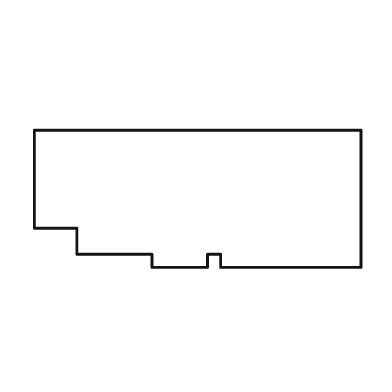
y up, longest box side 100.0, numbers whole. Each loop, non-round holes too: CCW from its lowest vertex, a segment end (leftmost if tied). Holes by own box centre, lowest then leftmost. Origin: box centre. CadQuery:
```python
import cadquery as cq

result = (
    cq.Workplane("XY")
    .moveTo(-14.0, -21.0)
    .lineTo(3.0, -21.0)
    .lineTo(3.0, -17.0)
    .lineTo(7.0, -17.0)
    .lineTo(7.0, -21.0)
    .lineTo(50.0, -21.0)
    .lineTo(50.0, 21.0)
    .lineTo(-50.0, 21.0)
    .lineTo(-50.0, -9.0)
    .lineTo(-37.0, -9.0)
    .lineTo(-37.0, -17.0)
    .lineTo(-14.0, -17.0)
    .close()
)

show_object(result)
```